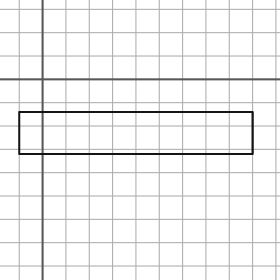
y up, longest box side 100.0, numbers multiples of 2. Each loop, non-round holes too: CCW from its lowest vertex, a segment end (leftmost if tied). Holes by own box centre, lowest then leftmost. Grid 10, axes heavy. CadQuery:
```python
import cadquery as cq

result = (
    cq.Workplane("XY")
    .moveTo(-10.0, -32.0)
    .lineTo(90.0, -32.0)
    .lineTo(90.0, -14.0)
    .lineTo(-10.0, -14.0)
    .close()
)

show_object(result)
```